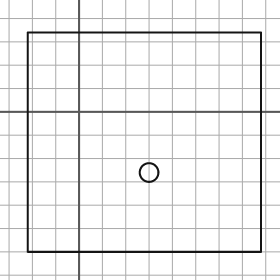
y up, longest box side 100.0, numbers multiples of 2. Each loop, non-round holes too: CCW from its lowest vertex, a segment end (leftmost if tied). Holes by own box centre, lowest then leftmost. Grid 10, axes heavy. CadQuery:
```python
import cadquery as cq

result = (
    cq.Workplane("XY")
    .moveTo(-22.0, -60.0)
    .lineTo(78.0, -60.0)
    .lineTo(78.0, 34.0)
    .lineTo(-22.0, 34.0)
    .close()
    .moveTo(30.0, -26.0)
    .circle(4.0)
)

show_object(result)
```